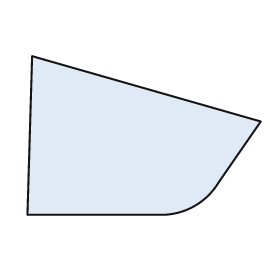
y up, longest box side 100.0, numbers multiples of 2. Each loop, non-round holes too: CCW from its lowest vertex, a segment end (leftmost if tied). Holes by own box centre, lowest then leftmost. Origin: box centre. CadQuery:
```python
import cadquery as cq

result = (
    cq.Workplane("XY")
    .moveTo(-50.0, -34.0)
    .lineTo(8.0, -34.0)
    .threePointArc((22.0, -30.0), (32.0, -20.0))
    .lineTo(50.0, 6.0)
    .lineTo(-48.0, 34.0)
    .close()
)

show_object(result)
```